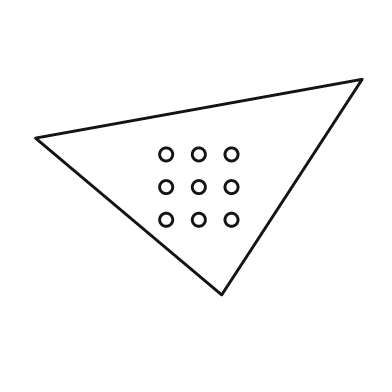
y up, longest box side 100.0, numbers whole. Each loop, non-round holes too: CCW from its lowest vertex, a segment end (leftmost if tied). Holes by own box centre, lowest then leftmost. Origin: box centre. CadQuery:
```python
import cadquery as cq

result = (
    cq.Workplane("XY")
    .moveTo(7.0, -33.0)
    .lineTo(50.0, 33.0)
    .lineTo(-50.0, 15.0)
    .close()
    .moveTo(-10.0, -10.0)
    .circle(2.0)
    .moveTo(0.0, -10.0)
    .circle(2.0)
    .moveTo(10.0, -10.0)
    .circle(2.0)
    .moveTo(-10.0, 0.0)
    .circle(2.0)
    .moveTo(0.0, 0.0)
    .circle(2.0)
    .moveTo(10.0, 0.0)
    .circle(2.0)
    .moveTo(-10.0, 10.0)
    .circle(2.0)
    .moveTo(0.0, 10.0)
    .circle(2.0)
    .moveTo(10.0, 10.0)
    .circle(2.0)
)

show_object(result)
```